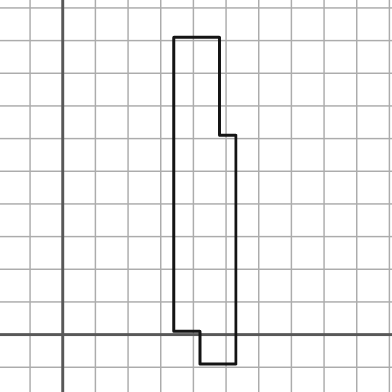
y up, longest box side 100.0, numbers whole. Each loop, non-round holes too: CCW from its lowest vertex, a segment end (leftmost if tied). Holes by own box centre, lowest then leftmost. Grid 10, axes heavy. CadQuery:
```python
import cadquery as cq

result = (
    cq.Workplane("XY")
    .moveTo(42.0, -9.0)
    .lineTo(53.0, -9.0)
    .lineTo(53.0, 61.0)
    .lineTo(48.0, 61.0)
    .lineTo(48.0, 91.0)
    .lineTo(34.0, 91.0)
    .lineTo(34.0, 1.0)
    .lineTo(42.0, 1.0)
    .close()
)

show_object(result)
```